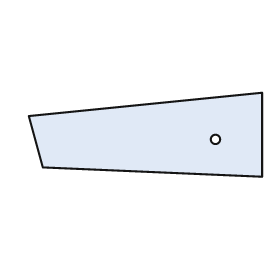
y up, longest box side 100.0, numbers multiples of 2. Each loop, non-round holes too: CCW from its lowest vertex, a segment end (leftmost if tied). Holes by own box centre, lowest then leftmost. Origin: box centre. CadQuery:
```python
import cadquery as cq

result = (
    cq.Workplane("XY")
    .moveTo(50.0, -18.0)
    .lineTo(50.0, 18.0)
    .lineTo(-50.0, 8.0)
    .lineTo(-44.0, -14.0)
    .close()
    .moveTo(30.0, -2.0)
    .circle(2.0)
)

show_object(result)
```